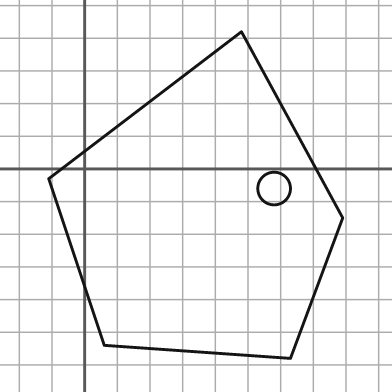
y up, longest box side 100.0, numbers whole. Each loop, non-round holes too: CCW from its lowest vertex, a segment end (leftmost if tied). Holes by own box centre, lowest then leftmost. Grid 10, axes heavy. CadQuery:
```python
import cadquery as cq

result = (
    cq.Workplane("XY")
    .moveTo(63.0, -58.0)
    .lineTo(79.0, -15.0)
    .lineTo(48.0, 42.0)
    .lineTo(-11.0, -3.0)
    .lineTo(6.0, -54.0)
    .close()
    .moveTo(58.0, -6.0)
    .circle(5.0)
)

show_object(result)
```